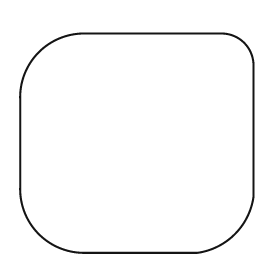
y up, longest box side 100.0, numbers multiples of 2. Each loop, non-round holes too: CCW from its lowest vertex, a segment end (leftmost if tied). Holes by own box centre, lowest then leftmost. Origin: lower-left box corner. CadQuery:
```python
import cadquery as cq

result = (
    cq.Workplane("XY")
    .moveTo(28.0, 0.0)
    .lineTo(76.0, 0.0)
    .threePointArc((92.0, 8.0), (100.0, 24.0))
    .lineTo(100.0, 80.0)
    .threePointArc((96.0, 90.0), (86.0, 94.0))
    .lineTo(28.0, 94.0)
    .threePointArc((8.0, 86.0), (0.0, 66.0))
    .lineTo(0.0, 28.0)
    .threePointArc((8.0, 8.0), (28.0, 0.0))
    .close()
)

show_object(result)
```